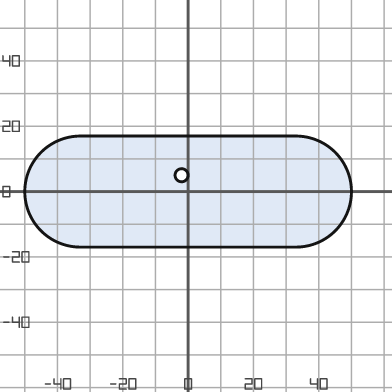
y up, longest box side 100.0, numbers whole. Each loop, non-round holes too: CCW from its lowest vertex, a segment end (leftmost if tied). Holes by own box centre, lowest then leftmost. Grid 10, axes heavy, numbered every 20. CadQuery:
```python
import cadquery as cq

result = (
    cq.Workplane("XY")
    .moveTo(-33.0, -17.0)
    .lineTo(33.0, -17.0)
    .threePointArc((50.0, 0.0), (33.0, 17.0))
    .lineTo(-33.0, 17.0)
    .threePointArc((-50.0, 0.0), (-33.0, -17.0))
    .close()
    .moveTo(-2.0, 5.0)
    .circle(2.0)
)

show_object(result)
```